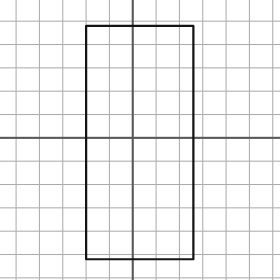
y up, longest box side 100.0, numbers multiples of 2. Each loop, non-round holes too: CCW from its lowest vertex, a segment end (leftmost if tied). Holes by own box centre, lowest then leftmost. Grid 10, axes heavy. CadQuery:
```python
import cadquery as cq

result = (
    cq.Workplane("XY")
    .moveTo(-20.0, -52.0)
    .lineTo(26.0, -52.0)
    .lineTo(26.0, 48.0)
    .lineTo(-20.0, 48.0)
    .close()
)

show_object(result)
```